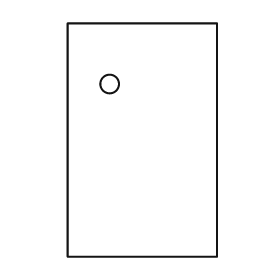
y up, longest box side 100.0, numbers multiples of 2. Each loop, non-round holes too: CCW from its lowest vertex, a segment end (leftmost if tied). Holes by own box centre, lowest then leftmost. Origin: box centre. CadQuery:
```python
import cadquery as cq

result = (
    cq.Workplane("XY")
    .moveTo(-32.0, -50.0)
    .lineTo(32.0, -50.0)
    .lineTo(32.0, 50.0)
    .lineTo(-32.0, 50.0)
    .close()
    .moveTo(-14.0, 24.0)
    .circle(4.0)
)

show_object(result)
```